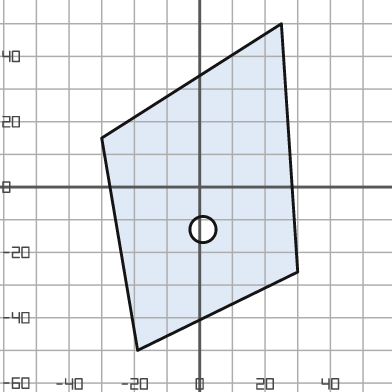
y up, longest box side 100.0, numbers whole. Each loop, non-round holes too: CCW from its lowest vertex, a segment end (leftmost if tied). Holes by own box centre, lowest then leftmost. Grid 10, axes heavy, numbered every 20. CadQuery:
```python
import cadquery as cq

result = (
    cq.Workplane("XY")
    .moveTo(-19.0, -50.0)
    .lineTo(30.0, -26.0)
    .lineTo(25.0, 50.0)
    .lineTo(-30.0, 15.0)
    .close()
    .moveTo(1.0, -13.0)
    .circle(4.0)
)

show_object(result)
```